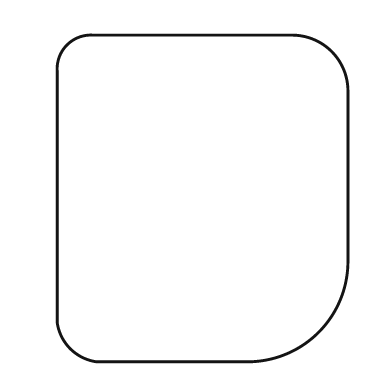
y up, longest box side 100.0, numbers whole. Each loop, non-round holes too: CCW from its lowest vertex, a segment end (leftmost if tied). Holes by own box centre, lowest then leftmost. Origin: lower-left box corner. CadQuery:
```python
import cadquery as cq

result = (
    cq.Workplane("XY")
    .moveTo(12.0, 0.0)
    .lineTo(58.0, 0.0)
    .threePointArc((80.0, 9.0), (89.0, 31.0))
    .lineTo(89.0, 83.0)
    .threePointArc((84.0, 95.0), (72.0, 100.0))
    .lineTo(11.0, 100.0)
    .threePointArc((3.0, 97.0), (0.0, 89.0))
    .lineTo(0.0, 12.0)
    .threePointArc((4.0, 4.0), (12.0, 0.0))
    .close()
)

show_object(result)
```